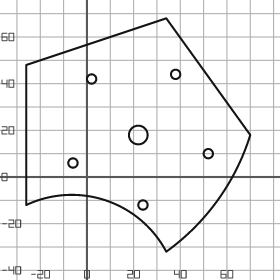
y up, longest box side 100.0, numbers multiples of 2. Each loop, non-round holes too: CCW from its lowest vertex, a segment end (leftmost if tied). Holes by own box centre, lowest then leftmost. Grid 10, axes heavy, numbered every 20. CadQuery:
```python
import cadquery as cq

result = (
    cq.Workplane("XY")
    .moveTo(34.0, -32.0)
    .threePointArc((56.0, -10.0), (70.0, 18.0))
    .lineTo(34.0, 68.0)
    .lineTo(-26.0, 48.0)
    .lineTo(-26.0, -12.0)
    .threePointArc((8.0, -10.0), (34.0, -32.0))
    .close()
    .moveTo(24.0, -12.0)
    .circle(2.0)
    .moveTo(-6.0, 6.0)
    .circle(2.0)
    .moveTo(52.0, 10.0)
    .circle(2.0)
    .moveTo(22.0, 18.0)
    .circle(4.0)
    .moveTo(2.0, 42.0)
    .circle(2.0)
    .moveTo(38.0, 44.0)
    .circle(2.0)
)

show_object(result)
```